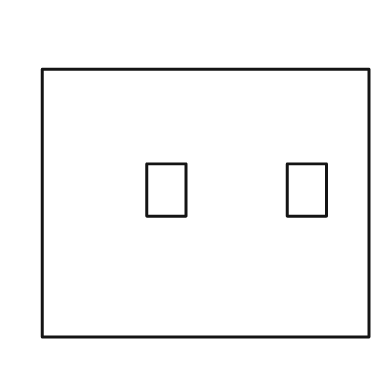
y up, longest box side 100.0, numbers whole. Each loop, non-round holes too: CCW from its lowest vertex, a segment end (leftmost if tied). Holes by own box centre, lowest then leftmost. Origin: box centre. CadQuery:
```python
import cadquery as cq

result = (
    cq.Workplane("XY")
    .moveTo(-50.0, -41.0)
    .lineTo(50.0, -41.0)
    .lineTo(50.0, 41.0)
    .lineTo(-50.0, 41.0)
    .close()
    .moveTo(-18.0, -4.0)
    .lineTo(-6.0, -4.0)
    .lineTo(-6.0, 12.0)
    .lineTo(-18.0, 12.0)
    .close()
    .moveTo(25.0, -4.0)
    .lineTo(37.0, -4.0)
    .lineTo(37.0, 12.0)
    .lineTo(25.0, 12.0)
    .close()
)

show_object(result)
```